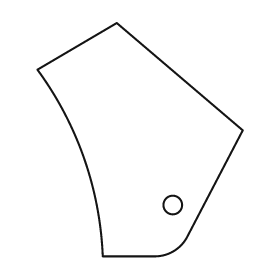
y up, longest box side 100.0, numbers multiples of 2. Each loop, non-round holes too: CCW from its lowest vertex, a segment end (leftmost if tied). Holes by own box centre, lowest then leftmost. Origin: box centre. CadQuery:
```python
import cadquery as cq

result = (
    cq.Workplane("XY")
    .moveTo(-16.0, -50.0)
    .lineTo(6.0, -50.0)
    .threePointArc((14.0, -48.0), (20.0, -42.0))
    .lineTo(44.0, 4.0)
    .lineTo(-10.0, 50.0)
    .lineTo(-44.0, 30.0)
    .threePointArc((-24.0, -8.0), (-16.0, -50.0))
    .close()
    .moveTo(14.0, -28.0)
    .circle(4.0)
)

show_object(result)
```